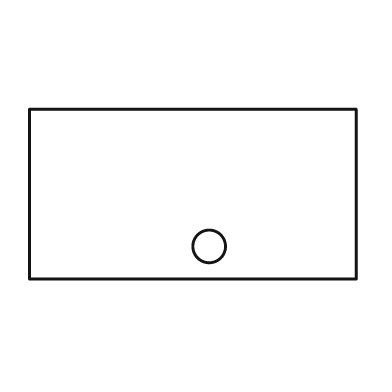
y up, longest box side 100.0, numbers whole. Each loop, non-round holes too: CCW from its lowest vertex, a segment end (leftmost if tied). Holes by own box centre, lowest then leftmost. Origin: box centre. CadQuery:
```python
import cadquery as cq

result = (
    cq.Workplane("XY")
    .moveTo(-50.0, -26.0)
    .lineTo(50.0, -26.0)
    .lineTo(50.0, 26.0)
    .lineTo(-50.0, 26.0)
    .close()
    .moveTo(5.0, -16.0)
    .circle(5.0)
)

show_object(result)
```